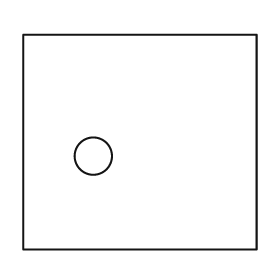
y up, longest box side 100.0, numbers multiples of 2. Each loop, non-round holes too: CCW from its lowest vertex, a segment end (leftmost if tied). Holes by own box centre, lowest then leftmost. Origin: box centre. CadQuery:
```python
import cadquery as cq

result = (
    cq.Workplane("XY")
    .moveTo(-50.0, -46.0)
    .lineTo(50.0, -46.0)
    .lineTo(50.0, 46.0)
    .lineTo(-50.0, 46.0)
    .close()
    .moveTo(-20.0, -6.0)
    .circle(8.0)
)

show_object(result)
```